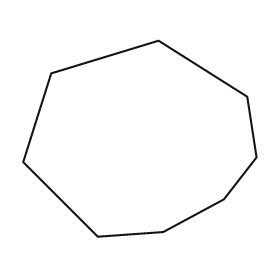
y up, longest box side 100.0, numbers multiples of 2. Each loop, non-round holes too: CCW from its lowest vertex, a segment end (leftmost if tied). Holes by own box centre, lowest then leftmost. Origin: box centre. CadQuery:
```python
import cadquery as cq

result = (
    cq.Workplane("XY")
    .moveTo(-18.0, -42.0)
    .lineTo(10.0, -40.0)
    .lineTo(36.0, -26.0)
    .lineTo(50.0, -8.0)
    .lineTo(46.0, 18.0)
    .lineTo(8.0, 42.0)
    .lineTo(-38.0, 28.0)
    .lineTo(-50.0, -10.0)
    .close()
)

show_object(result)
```